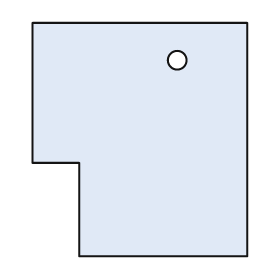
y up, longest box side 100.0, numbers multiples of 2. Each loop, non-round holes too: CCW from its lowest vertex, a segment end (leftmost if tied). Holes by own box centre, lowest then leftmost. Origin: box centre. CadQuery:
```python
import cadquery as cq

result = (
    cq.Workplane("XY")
    .moveTo(-26.0, -50.0)
    .lineTo(46.0, -50.0)
    .lineTo(46.0, 50.0)
    .lineTo(-46.0, 50.0)
    .lineTo(-46.0, -10.0)
    .lineTo(-26.0, -10.0)
    .close()
    .moveTo(16.0, 34.0)
    .circle(4.0)
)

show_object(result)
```